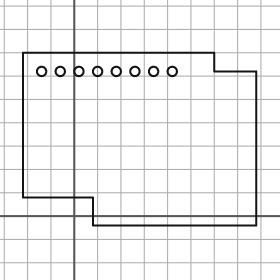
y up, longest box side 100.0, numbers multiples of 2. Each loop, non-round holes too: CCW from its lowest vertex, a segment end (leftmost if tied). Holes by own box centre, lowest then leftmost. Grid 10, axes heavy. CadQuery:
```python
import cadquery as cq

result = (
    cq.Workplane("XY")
    .moveTo(8.0, -4.0)
    .lineTo(78.0, -4.0)
    .lineTo(78.0, 62.0)
    .lineTo(60.0, 62.0)
    .lineTo(60.0, 70.0)
    .lineTo(-22.0, 70.0)
    .lineTo(-22.0, 8.0)
    .lineTo(8.0, 8.0)
    .close()
    .moveTo(-14.0, 62.0)
    .circle(2.0)
    .moveTo(-6.0, 62.0)
    .circle(2.0)
    .moveTo(2.0, 62.0)
    .circle(2.0)
    .moveTo(10.0, 62.0)
    .circle(2.0)
    .moveTo(18.0, 62.0)
    .circle(2.0)
    .moveTo(26.0, 62.0)
    .circle(2.0)
    .moveTo(34.0, 62.0)
    .circle(2.0)
    .moveTo(42.0, 62.0)
    .circle(2.0)
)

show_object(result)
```